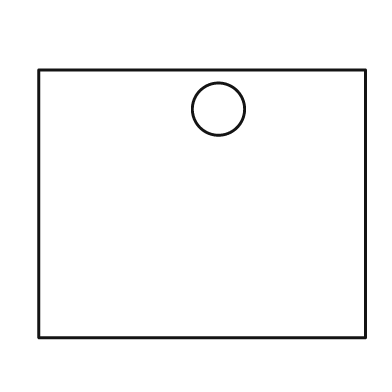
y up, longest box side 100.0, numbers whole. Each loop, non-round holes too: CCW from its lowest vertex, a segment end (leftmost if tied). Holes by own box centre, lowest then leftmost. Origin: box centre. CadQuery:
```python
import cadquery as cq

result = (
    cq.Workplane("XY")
    .moveTo(-50.0, -41.0)
    .lineTo(50.0, -41.0)
    .lineTo(50.0, 41.0)
    .lineTo(-50.0, 41.0)
    .close()
    .moveTo(5.0, 29.0)
    .circle(8.0)
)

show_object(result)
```